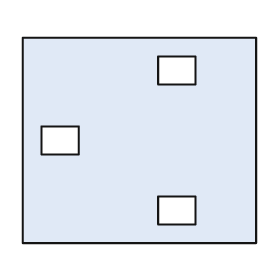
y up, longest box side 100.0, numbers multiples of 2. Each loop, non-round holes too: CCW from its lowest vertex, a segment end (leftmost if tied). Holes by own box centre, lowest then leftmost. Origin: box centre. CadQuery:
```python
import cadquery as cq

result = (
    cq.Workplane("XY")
    .moveTo(-50.0, -44.0)
    .lineTo(50.0, -44.0)
    .lineTo(50.0, 44.0)
    .lineTo(-50.0, 44.0)
    .close()
    .moveTo(8.0, -36.0)
    .lineTo(24.0, -36.0)
    .lineTo(24.0, -24.0)
    .lineTo(8.0, -24.0)
    .close()
    .moveTo(-42.0, -6.0)
    .lineTo(-26.0, -6.0)
    .lineTo(-26.0, 6.0)
    .lineTo(-42.0, 6.0)
    .close()
    .moveTo(8.0, 24.0)
    .lineTo(24.0, 24.0)
    .lineTo(24.0, 36.0)
    .lineTo(8.0, 36.0)
    .close()
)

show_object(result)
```